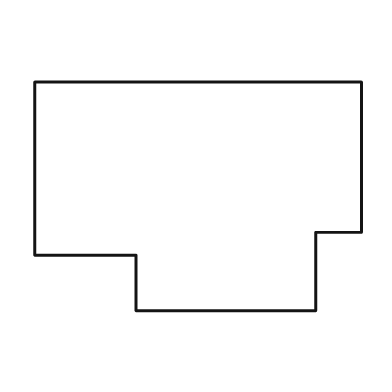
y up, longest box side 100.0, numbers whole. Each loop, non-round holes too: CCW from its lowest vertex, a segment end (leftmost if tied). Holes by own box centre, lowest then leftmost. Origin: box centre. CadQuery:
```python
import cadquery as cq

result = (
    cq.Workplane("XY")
    .moveTo(-19.0, -35.0)
    .lineTo(36.0, -35.0)
    .lineTo(36.0, -11.0)
    .lineTo(50.0, -11.0)
    .lineTo(50.0, 35.0)
    .lineTo(-50.0, 35.0)
    .lineTo(-50.0, -18.0)
    .lineTo(-19.0, -18.0)
    .close()
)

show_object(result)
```